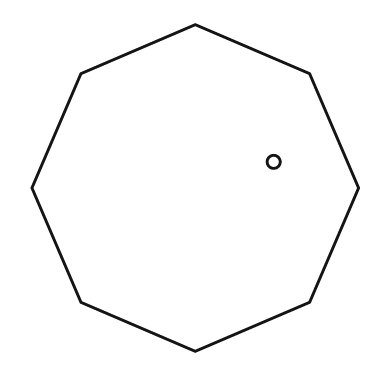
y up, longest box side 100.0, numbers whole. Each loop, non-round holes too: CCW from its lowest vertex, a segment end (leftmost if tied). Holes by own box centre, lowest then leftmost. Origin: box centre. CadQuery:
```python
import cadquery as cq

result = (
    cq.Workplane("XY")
    .moveTo(0.0, -50.0)
    .lineTo(35.0, -35.0)
    .lineTo(50.0, 0.0)
    .lineTo(35.0, 35.0)
    .lineTo(0.0, 50.0)
    .lineTo(-35.0, 35.0)
    .lineTo(-50.0, 0.0)
    .lineTo(-35.0, -35.0)
    .close()
    .moveTo(24.0, 8.0)
    .circle(2.0)
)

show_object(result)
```